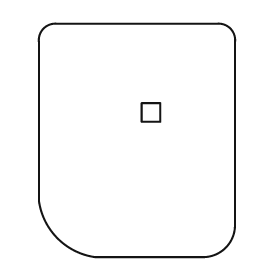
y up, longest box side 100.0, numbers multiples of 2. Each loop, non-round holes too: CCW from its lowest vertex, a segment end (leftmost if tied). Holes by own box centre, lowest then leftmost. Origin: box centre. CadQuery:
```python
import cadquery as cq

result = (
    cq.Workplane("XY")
    .moveTo(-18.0, -50.0)
    .lineTo(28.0, -50.0)
    .threePointArc((38.0, -46.0), (42.0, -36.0))
    .lineTo(42.0, 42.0)
    .threePointArc((40.0, 48.0), (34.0, 50.0))
    .lineTo(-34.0, 50.0)
    .threePointArc((-40.0, 48.0), (-42.0, 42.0))
    .lineTo(-42.0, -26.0)
    .threePointArc((-34.0, -42.0), (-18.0, -50.0))
    .close()
    .moveTo(2.0, 8.0)
    .lineTo(10.0, 8.0)
    .lineTo(10.0, 16.0)
    .lineTo(2.0, 16.0)
    .close()
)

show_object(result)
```